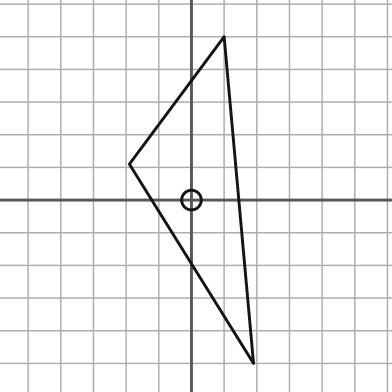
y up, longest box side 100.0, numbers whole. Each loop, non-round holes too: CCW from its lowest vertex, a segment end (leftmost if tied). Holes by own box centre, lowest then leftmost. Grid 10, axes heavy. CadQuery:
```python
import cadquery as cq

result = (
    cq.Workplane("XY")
    .moveTo(19.0, -50.0)
    .lineTo(10.0, 50.0)
    .lineTo(-19.0, 11.0)
    .close()
    .moveTo(0.0, 0.0)
    .circle(3.0)
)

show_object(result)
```